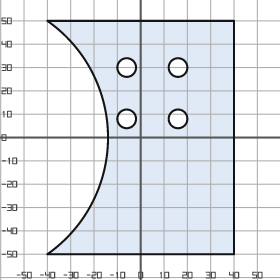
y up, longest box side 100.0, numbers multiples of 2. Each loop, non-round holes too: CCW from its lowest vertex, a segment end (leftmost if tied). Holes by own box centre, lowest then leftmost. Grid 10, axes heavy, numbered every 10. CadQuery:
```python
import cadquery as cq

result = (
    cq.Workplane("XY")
    .moveTo(-40.0, -50.0)
    .lineTo(40.0, -50.0)
    .lineTo(40.0, 50.0)
    .lineTo(-40.0, 50.0)
    .threePointArc((-14.0, 0.0), (-40.0, -50.0))
    .close()
    .moveTo(-6.0, 8.0)
    .circle(4.0)
    .moveTo(16.0, 8.0)
    .circle(4.0)
    .moveTo(-6.0, 30.0)
    .circle(4.0)
    .moveTo(16.0, 30.0)
    .circle(4.0)
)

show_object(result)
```